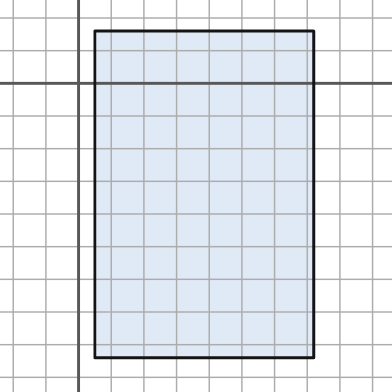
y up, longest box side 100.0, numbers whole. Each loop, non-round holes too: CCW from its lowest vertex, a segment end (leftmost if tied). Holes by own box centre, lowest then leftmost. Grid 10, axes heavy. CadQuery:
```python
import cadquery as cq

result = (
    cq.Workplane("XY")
    .moveTo(5.0, -84.0)
    .lineTo(72.0, -84.0)
    .lineTo(72.0, 16.0)
    .lineTo(5.0, 16.0)
    .close()
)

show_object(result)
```